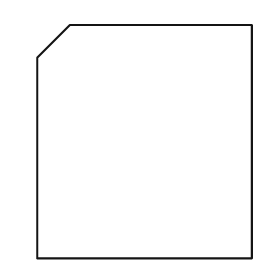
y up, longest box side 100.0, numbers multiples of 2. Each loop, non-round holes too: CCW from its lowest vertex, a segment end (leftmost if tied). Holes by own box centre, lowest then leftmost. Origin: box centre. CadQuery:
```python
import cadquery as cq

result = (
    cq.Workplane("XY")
    .moveTo(-46.0, -50.0)
    .lineTo(46.0, -50.0)
    .lineTo(46.0, 50.0)
    .lineTo(-32.0, 50.0)
    .lineTo(-46.0, 36.0)
    .close()
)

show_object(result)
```